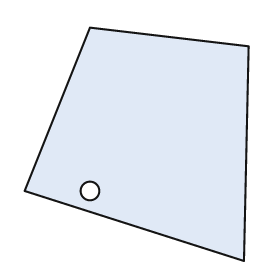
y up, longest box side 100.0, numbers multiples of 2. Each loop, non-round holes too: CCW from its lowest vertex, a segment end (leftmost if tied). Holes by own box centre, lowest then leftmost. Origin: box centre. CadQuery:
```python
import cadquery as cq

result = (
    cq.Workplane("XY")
    .moveTo(46.0, -50.0)
    .lineTo(48.0, 42.0)
    .lineTo(-20.0, 50.0)
    .lineTo(-48.0, -20.0)
    .close()
    .moveTo(-20.0, -20.0)
    .circle(4.0)
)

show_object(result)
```